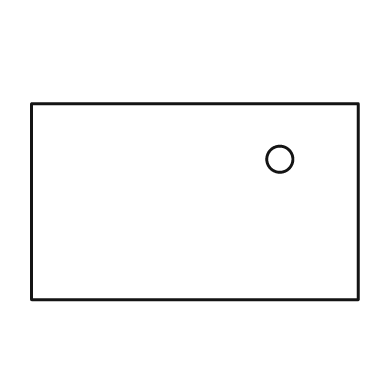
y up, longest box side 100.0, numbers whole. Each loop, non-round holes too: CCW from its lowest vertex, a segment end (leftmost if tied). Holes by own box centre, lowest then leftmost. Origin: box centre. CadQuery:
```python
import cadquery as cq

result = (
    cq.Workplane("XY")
    .moveTo(-50.0, -30.0)
    .lineTo(50.0, -30.0)
    .lineTo(50.0, 30.0)
    .lineTo(-50.0, 30.0)
    .close()
    .moveTo(26.0, 13.0)
    .circle(4.0)
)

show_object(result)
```